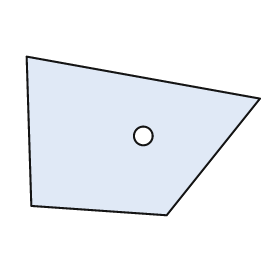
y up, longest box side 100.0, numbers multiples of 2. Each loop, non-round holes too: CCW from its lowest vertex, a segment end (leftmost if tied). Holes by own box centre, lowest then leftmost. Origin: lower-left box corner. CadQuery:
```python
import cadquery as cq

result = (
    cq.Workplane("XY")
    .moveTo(60.0, 0.0)
    .lineTo(100.0, 50.0)
    .lineTo(0.0, 68.0)
    .lineTo(2.0, 4.0)
    .close()
    .moveTo(50.0, 34.0)
    .circle(4.0)
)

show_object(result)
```